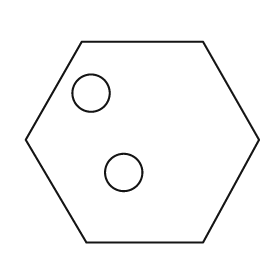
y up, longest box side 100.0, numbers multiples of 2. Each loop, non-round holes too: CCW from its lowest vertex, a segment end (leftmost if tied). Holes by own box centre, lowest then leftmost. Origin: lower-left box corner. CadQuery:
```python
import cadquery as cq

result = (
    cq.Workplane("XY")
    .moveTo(26.0, 0.0)
    .lineTo(76.0, 0.0)
    .lineTo(100.0, 44.0)
    .lineTo(76.0, 86.0)
    .lineTo(24.0, 86.0)
    .lineTo(0.0, 44.0)
    .close()
    .moveTo(42.0, 30.0)
    .circle(8.0)
    .moveTo(28.0, 64.0)
    .circle(8.0)
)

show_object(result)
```